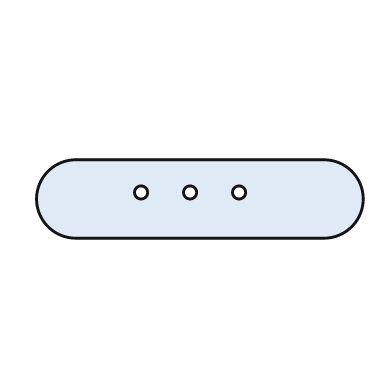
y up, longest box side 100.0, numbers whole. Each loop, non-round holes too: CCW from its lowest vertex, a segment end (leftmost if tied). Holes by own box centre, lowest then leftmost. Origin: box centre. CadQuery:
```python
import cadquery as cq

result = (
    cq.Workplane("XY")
    .moveTo(-38.0, -12.0)
    .lineTo(38.0, -12.0)
    .threePointArc((50.0, 0.0), (38.0, 12.0))
    .lineTo(-38.0, 12.0)
    .threePointArc((-50.0, 0.0), (-38.0, -12.0))
    .close()
    .moveTo(-18.0, 2.0)
    .circle(2.0)
    .moveTo(-3.0, 2.0)
    .circle(2.0)
    .moveTo(12.0, 2.0)
    .circle(2.0)
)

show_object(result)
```